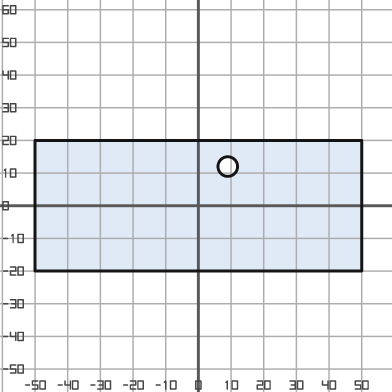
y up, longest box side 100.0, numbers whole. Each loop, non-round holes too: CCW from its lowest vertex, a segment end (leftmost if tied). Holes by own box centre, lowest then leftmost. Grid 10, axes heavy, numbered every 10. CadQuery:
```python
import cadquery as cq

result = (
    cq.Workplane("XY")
    .moveTo(-50.0, -20.0)
    .lineTo(50.0, -20.0)
    .lineTo(50.0, 20.0)
    .lineTo(-50.0, 20.0)
    .close()
    .moveTo(9.0, 12.0)
    .circle(3.0)
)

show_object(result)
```